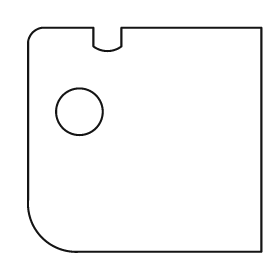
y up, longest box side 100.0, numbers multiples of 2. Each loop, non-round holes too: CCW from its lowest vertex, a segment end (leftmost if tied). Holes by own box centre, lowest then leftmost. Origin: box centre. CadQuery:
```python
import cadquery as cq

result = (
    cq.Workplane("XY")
    .moveTo(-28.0, -48.0)
    .lineTo(50.0, -48.0)
    .lineTo(50.0, 48.0)
    .lineTo(-10.0, 48.0)
    .lineTo(-10.0, 40.0)
    .threePointArc((-16.0, 38.0), (-22.0, 40.0))
    .lineTo(-22.0, 48.0)
    .lineTo(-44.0, 48.0)
    .threePointArc((-48.0, 46.0), (-50.0, 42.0))
    .lineTo(-50.0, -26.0)
    .threePointArc((-44.0, -42.0), (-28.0, -48.0))
    .close()
    .moveTo(-28.0, 12.0)
    .circle(10.0)
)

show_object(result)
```